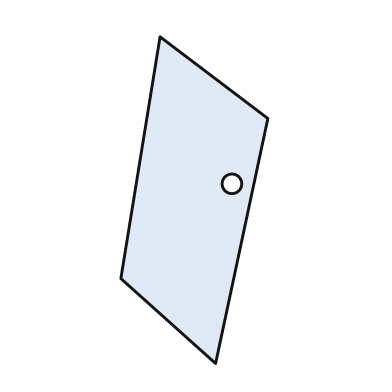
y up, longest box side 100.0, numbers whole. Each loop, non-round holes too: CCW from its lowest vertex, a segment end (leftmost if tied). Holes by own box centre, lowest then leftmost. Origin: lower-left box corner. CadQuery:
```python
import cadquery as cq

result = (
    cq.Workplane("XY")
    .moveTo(29.0, 0.0)
    .lineTo(45.0, 75.0)
    .lineTo(12.0, 100.0)
    .lineTo(0.0, 26.0)
    .close()
    .moveTo(34.0, 55.0)
    .circle(3.0)
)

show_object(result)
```